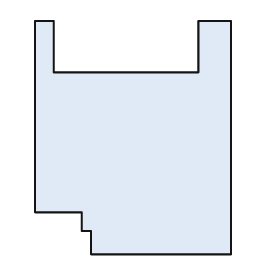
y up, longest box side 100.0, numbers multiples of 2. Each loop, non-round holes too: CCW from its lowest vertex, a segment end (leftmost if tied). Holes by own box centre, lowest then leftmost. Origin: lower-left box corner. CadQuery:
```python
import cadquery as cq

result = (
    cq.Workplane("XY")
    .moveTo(24.0, 0.0)
    .lineTo(84.0, 0.0)
    .lineTo(84.0, 100.0)
    .lineTo(70.0, 100.0)
    .lineTo(70.0, 78.0)
    .lineTo(8.0, 78.0)
    .lineTo(8.0, 100.0)
    .lineTo(0.0, 100.0)
    .lineTo(0.0, 18.0)
    .lineTo(20.0, 18.0)
    .lineTo(20.0, 10.0)
    .lineTo(24.0, 10.0)
    .close()
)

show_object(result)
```